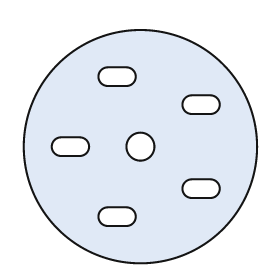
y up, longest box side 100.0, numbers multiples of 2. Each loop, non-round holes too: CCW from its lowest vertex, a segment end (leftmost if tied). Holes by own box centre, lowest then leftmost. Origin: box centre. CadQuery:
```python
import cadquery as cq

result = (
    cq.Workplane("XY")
    .moveTo(0.0, 0.0)
    .circle(50.0)
    .moveTo(-14.0, -34.0)
    .lineTo(-6.0, -34.0)
    .threePointArc((-2.0, -30.0), (-6.0, -26.0))
    .lineTo(-14.0, -26.0)
    .threePointArc((-18.0, -30.0), (-14.0, -34.0))
    .close()
    .moveTo(22.0, -22.0)
    .lineTo(30.0, -22.0)
    .threePointArc((34.0, -18.0), (30.0, -14.0))
    .lineTo(22.0, -14.0)
    .threePointArc((18.0, -18.0), (22.0, -22.0))
    .close()
    .moveTo(-34.0, -4.0)
    .lineTo(-26.0, -4.0)
    .threePointArc((-22.0, 0.0), (-26.0, 4.0))
    .lineTo(-34.0, 4.0)
    .threePointArc((-38.0, 0.0), (-34.0, -4.0))
    .close()
    .moveTo(0.0, 0.0)
    .circle(6.0)
    .moveTo(22.0, 14.0)
    .lineTo(30.0, 14.0)
    .threePointArc((34.0, 18.0), (30.0, 22.0))
    .lineTo(22.0, 22.0)
    .threePointArc((18.0, 18.0), (22.0, 14.0))
    .close()
    .moveTo(-14.0, 26.0)
    .lineTo(-6.0, 26.0)
    .threePointArc((-2.0, 30.0), (-6.0, 34.0))
    .lineTo(-14.0, 34.0)
    .threePointArc((-18.0, 30.0), (-14.0, 26.0))
    .close()
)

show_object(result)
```